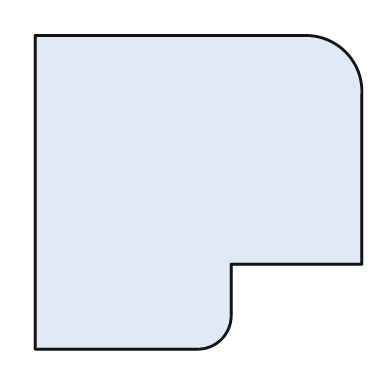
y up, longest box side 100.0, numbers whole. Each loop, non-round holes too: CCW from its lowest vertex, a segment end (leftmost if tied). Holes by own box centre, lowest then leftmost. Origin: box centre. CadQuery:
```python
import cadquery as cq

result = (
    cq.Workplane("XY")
    .moveTo(-50.0, -48.0)
    .lineTo(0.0, -48.0)
    .threePointArc((7.0, -45.0), (10.0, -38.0))
    .lineTo(10.0, -22.0)
    .lineTo(50.0, -22.0)
    .lineTo(50.0, 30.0)
    .threePointArc((45.0, 43.0), (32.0, 48.0))
    .lineTo(-50.0, 48.0)
    .close()
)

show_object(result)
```